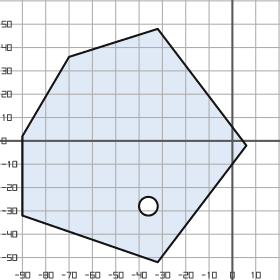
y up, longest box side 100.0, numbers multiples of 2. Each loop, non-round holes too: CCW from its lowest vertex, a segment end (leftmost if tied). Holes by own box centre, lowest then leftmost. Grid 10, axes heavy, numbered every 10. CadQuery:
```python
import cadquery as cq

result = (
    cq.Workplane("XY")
    .moveTo(-32.0, -52.0)
    .lineTo(6.0, -2.0)
    .lineTo(-32.0, 48.0)
    .lineTo(-70.0, 36.0)
    .lineTo(-90.0, 2.0)
    .lineTo(-90.0, -32.0)
    .close()
    .moveTo(-36.0, -28.0)
    .circle(4.0)
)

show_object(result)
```